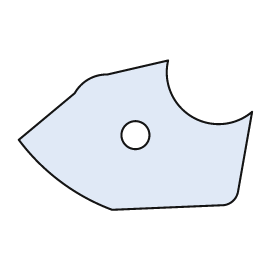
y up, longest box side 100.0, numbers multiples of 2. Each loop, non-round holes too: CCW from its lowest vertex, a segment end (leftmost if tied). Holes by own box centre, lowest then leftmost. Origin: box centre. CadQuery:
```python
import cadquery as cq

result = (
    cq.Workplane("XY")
    .moveTo(-10.0, -32.0)
    .lineTo(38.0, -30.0)
    .threePointArc((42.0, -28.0), (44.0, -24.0))
    .lineTo(50.0, 10.0)
    .threePointArc((24.0, 8.0), (14.0, 32.0))
    .lineTo(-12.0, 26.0)
    .threePointArc((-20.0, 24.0), (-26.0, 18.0))
    .lineTo(-50.0, -2.0)
    .threePointArc((-32.0, -20.0), (-10.0, -32.0))
    .close()
    .moveTo(0.0, 0.0)
    .circle(6.0)
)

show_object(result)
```